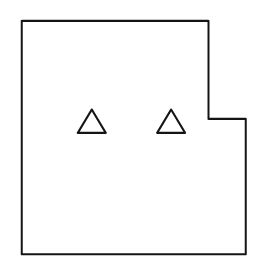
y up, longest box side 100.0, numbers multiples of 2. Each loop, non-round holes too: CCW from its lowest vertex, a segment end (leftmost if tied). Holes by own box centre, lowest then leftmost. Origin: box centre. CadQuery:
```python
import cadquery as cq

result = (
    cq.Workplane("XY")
    .moveTo(-48.0, -50.0)
    .lineTo(48.0, -50.0)
    .lineTo(48.0, 8.0)
    .lineTo(32.0, 8.0)
    .lineTo(32.0, 50.0)
    .lineTo(-48.0, 50.0)
    .close()
    .moveTo(-24.0, 2.0)
    .lineTo(-12.0, 2.0)
    .lineTo(-18.0, 12.0)
    .close()
    .moveTo(10.0, 2.0)
    .lineTo(22.0, 2.0)
    .lineTo(16.0, 12.0)
    .close()
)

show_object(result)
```